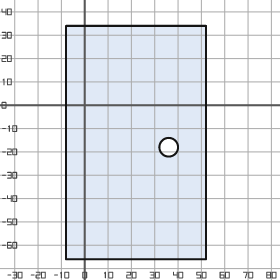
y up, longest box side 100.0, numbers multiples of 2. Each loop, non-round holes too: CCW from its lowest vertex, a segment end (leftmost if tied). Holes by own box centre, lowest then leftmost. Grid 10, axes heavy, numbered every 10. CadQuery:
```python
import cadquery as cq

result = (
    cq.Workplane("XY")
    .moveTo(-8.0, -66.0)
    .lineTo(52.0, -66.0)
    .lineTo(52.0, 34.0)
    .lineTo(-8.0, 34.0)
    .close()
    .moveTo(36.0, -18.0)
    .circle(4.0)
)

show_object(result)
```